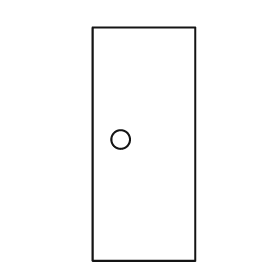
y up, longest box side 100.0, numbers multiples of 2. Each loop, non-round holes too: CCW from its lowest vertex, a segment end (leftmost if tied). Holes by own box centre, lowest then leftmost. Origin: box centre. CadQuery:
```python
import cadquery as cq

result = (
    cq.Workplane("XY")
    .moveTo(-22.0, -50.0)
    .lineTo(22.0, -50.0)
    .lineTo(22.0, 50.0)
    .lineTo(-22.0, 50.0)
    .close()
    .moveTo(-10.0, 2.0)
    .circle(4.0)
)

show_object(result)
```